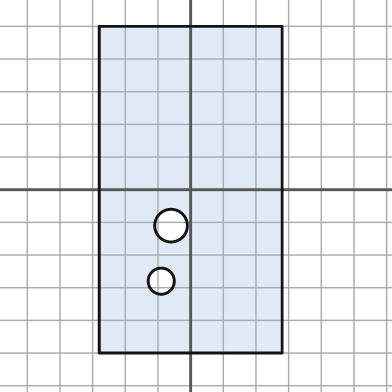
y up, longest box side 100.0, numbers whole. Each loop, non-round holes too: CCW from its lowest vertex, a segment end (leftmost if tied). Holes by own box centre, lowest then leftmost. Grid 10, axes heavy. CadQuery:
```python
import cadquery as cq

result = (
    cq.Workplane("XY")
    .moveTo(-28.0, -50.0)
    .lineTo(28.0, -50.0)
    .lineTo(28.0, 50.0)
    .lineTo(-28.0, 50.0)
    .close()
    .moveTo(-9.0, -28.0)
    .circle(4.0)
    .moveTo(-6.0, -11.0)
    .circle(5.0)
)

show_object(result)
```